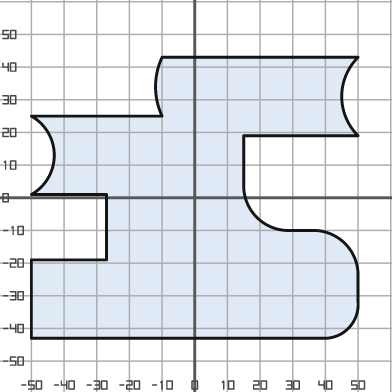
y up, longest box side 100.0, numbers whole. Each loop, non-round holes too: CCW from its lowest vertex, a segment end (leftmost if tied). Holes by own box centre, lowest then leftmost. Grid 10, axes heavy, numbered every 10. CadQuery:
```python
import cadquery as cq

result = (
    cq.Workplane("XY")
    .moveTo(-50.0, -43.0)
    .lineTo(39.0, -43.0)
    .threePointArc((47.0, -40.0), (50.0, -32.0))
    .lineTo(50.0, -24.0)
    .threePointArc((46.0, -14.0), (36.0, -10.0))
    .lineTo(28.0, -10.0)
    .threePointArc((19.0, -6.0), (15.0, 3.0))
    .lineTo(15.0, 19.0)
    .lineTo(50.0, 19.0)
    .threePointArc((45.0, 31.0), (50.0, 43.0))
    .lineTo(-10.0, 43.0)
    .threePointArc((-12.0, 34.0), (-10.0, 25.0))
    .lineTo(-50.0, 25.0)
    .threePointArc((-43.0, 13.0), (-50.0, 1.0))
    .lineTo(-27.0, 1.0)
    .lineTo(-27.0, -19.0)
    .lineTo(-50.0, -19.0)
    .close()
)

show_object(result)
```